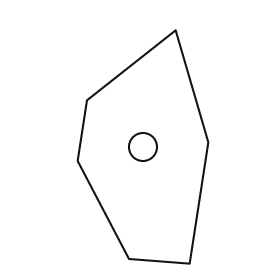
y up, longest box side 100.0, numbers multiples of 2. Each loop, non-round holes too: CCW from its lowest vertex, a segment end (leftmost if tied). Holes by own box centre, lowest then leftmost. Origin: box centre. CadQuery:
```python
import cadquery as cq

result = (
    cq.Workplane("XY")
    .moveTo(20.0, -50.0)
    .lineTo(28.0, 2.0)
    .lineTo(14.0, 50.0)
    .lineTo(-24.0, 20.0)
    .lineTo(-28.0, -6.0)
    .lineTo(-6.0, -48.0)
    .close()
    .moveTo(0.0, 0.0)
    .circle(6.0)
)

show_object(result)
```